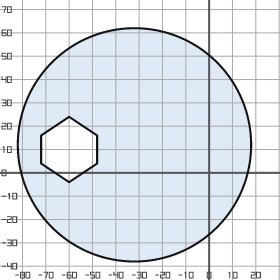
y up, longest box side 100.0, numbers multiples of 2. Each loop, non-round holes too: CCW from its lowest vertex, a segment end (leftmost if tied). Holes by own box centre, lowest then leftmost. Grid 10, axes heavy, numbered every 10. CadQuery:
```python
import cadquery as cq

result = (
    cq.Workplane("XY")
    .moveTo(-32.0, 12.0)
    .circle(50.0)
    .moveTo(-60.0, -4.0)
    .lineTo(-48.0, 4.0)
    .lineTo(-48.0, 16.0)
    .lineTo(-60.0, 24.0)
    .lineTo(-72.0, 16.0)
    .lineTo(-72.0, 4.0)
    .close()
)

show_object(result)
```